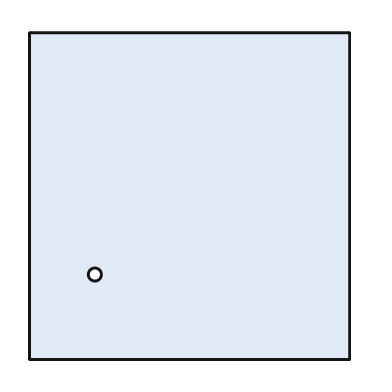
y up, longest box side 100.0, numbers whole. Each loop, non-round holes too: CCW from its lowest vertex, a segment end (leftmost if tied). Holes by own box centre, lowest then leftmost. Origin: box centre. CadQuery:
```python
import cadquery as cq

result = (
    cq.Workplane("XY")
    .moveTo(-49.0, -50.0)
    .lineTo(49.0, -50.0)
    .lineTo(49.0, 50.0)
    .lineTo(-49.0, 50.0)
    .close()
    .moveTo(-29.0, -24.0)
    .circle(2.0)
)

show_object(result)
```